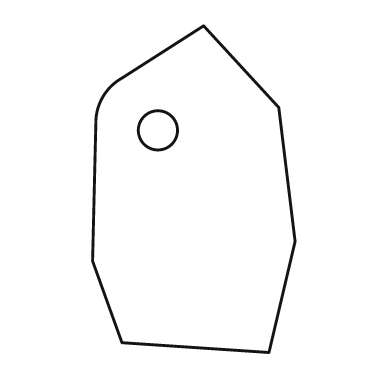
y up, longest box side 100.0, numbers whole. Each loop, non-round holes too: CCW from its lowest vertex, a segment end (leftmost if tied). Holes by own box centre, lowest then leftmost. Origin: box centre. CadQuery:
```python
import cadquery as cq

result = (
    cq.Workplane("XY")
    .moveTo(23.0, -50.0)
    .lineTo(31.0, -16.0)
    .lineTo(26.0, 25.0)
    .lineTo(3.0, 50.0)
    .lineTo(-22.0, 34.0)
    .threePointArc((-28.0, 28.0), (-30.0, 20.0))
    .lineTo(-31.0, -22.0)
    .lineTo(-22.0, -47.0)
    .close()
    .moveTo(-11.0, 18.0)
    .circle(6.0)
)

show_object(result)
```